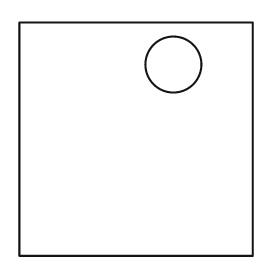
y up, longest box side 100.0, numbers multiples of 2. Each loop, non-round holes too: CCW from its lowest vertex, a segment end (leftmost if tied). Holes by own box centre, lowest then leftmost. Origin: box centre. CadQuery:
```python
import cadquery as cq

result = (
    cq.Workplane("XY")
    .moveTo(-50.0, -50.0)
    .lineTo(50.0, -50.0)
    .lineTo(50.0, 50.0)
    .lineTo(-50.0, 50.0)
    .close()
    .moveTo(16.0, 32.0)
    .circle(12.0)
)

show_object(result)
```